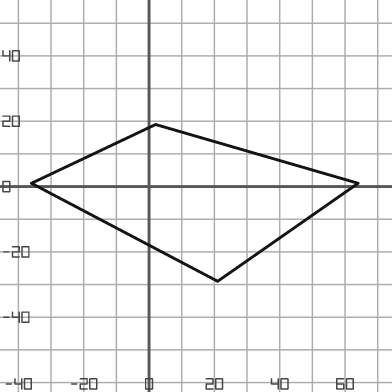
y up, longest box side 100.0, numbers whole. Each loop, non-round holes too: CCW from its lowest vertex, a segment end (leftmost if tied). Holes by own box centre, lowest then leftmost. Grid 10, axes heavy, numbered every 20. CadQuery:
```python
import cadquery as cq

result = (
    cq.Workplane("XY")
    .moveTo(21.0, -29.0)
    .lineTo(64.0, 1.0)
    .lineTo(2.0, 19.0)
    .lineTo(-36.0, 1.0)
    .close()
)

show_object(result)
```